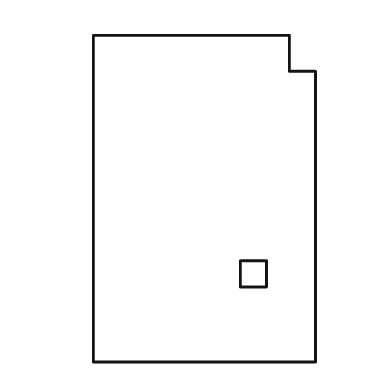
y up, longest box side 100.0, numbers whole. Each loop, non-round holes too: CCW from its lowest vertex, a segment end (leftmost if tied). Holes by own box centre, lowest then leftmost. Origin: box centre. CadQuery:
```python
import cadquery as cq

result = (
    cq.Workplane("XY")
    .moveTo(-34.0, -50.0)
    .lineTo(34.0, -50.0)
    .lineTo(34.0, 39.0)
    .lineTo(26.0, 39.0)
    .lineTo(26.0, 50.0)
    .lineTo(-34.0, 50.0)
    .close()
    .moveTo(11.0, -27.0)
    .lineTo(19.0, -27.0)
    .lineTo(19.0, -19.0)
    .lineTo(11.0, -19.0)
    .close()
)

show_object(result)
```